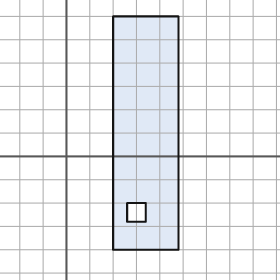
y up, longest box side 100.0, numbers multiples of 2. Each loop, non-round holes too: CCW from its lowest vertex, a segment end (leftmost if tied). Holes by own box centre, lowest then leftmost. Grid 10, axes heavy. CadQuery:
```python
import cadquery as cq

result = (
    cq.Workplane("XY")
    .moveTo(20.0, -40.0)
    .lineTo(48.0, -40.0)
    .lineTo(48.0, 60.0)
    .lineTo(20.0, 60.0)
    .close()
    .moveTo(26.0, -28.0)
    .lineTo(34.0, -28.0)
    .lineTo(34.0, -20.0)
    .lineTo(26.0, -20.0)
    .close()
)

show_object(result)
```